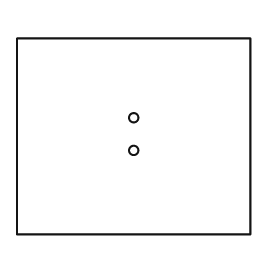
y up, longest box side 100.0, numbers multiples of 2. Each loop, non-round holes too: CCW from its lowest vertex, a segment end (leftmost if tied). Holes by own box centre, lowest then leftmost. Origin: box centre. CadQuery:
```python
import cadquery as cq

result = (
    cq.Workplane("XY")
    .moveTo(-50.0, -42.0)
    .lineTo(50.0, -42.0)
    .lineTo(50.0, 42.0)
    .lineTo(-50.0, 42.0)
    .close()
    .moveTo(0.0, -6.0)
    .circle(2.0)
    .moveTo(0.0, 8.0)
    .circle(2.0)
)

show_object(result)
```